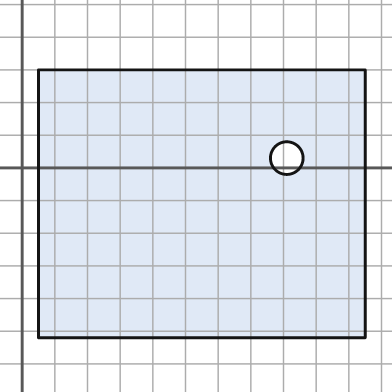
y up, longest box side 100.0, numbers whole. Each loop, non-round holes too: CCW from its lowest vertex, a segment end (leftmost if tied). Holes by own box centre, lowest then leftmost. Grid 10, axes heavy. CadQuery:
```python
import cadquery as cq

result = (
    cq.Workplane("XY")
    .moveTo(5.0, -52.0)
    .lineTo(105.0, -52.0)
    .lineTo(105.0, 30.0)
    .lineTo(5.0, 30.0)
    .close()
    .moveTo(81.0, 3.0)
    .circle(5.0)
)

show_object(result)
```